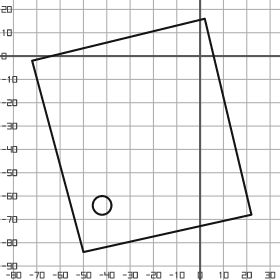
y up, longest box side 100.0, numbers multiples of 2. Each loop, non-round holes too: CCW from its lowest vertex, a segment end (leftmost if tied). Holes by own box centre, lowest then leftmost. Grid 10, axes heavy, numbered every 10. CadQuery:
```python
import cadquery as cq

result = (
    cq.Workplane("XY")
    .moveTo(-50.0, -84.0)
    .lineTo(22.0, -68.0)
    .lineTo(2.0, 16.0)
    .lineTo(-72.0, -2.0)
    .close()
    .moveTo(-42.0, -64.0)
    .circle(4.0)
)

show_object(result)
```